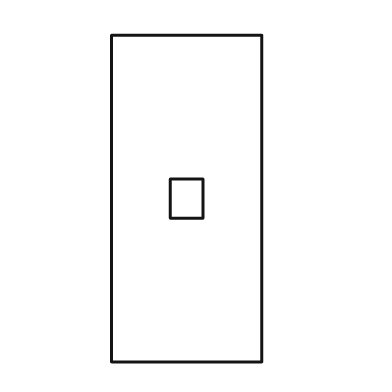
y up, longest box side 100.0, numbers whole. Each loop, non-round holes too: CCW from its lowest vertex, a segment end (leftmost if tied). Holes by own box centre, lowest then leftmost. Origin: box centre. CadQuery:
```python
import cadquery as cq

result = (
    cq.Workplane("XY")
    .moveTo(-23.0, -50.0)
    .lineTo(23.0, -50.0)
    .lineTo(23.0, 50.0)
    .lineTo(-23.0, 50.0)
    .close()
    .moveTo(-5.0, -6.0)
    .lineTo(5.0, -6.0)
    .lineTo(5.0, 6.0)
    .lineTo(-5.0, 6.0)
    .close()
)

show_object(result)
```